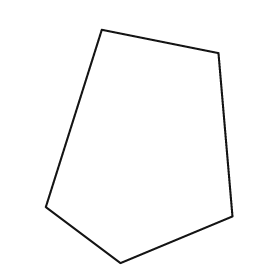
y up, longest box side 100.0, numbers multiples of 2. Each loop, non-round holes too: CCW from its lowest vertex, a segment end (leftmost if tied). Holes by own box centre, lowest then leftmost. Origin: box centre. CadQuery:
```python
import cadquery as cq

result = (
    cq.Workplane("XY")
    .moveTo(-8.0, -50.0)
    .lineTo(40.0, -30.0)
    .lineTo(34.0, 40.0)
    .lineTo(-16.0, 50.0)
    .lineTo(-40.0, -26.0)
    .close()
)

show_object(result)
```